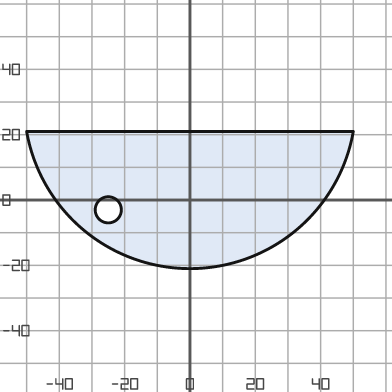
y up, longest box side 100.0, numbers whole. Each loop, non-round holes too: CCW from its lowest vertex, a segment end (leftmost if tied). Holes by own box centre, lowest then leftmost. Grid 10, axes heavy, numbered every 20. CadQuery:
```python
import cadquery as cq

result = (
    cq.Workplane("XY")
    .moveTo(-50.0, 21.0)
    .threePointArc((0.0, -21.0), (50.0, 21.0))
    .close()
    .moveTo(-25.0, -3.0)
    .circle(4.0)
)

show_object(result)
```